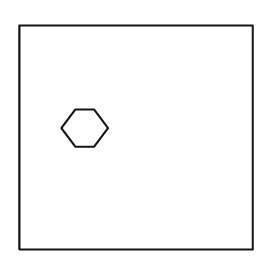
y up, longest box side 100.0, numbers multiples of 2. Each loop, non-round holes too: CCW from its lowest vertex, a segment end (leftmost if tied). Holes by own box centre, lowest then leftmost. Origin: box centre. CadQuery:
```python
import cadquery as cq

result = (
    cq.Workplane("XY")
    .moveTo(-50.0, -48.0)
    .lineTo(50.0, -48.0)
    .lineTo(50.0, 48.0)
    .lineTo(-50.0, 48.0)
    .close()
    .moveTo(-26.0, -4.0)
    .lineTo(-18.0, -4.0)
    .lineTo(-12.0, 4.0)
    .lineTo(-18.0, 12.0)
    .lineTo(-26.0, 12.0)
    .lineTo(-32.0, 4.0)
    .close()
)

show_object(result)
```